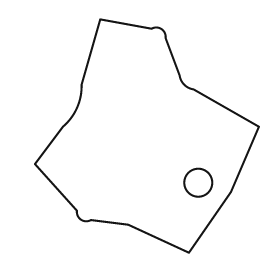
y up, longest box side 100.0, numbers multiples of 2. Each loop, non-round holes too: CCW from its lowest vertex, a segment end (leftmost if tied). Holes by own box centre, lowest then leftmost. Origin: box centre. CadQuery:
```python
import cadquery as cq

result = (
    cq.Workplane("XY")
    .moveTo(18.0, -50.0)
    .lineTo(36.0, -24.0)
    .lineTo(48.0, 4.0)
    .lineTo(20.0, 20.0)
    .threePointArc((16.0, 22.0), (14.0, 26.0))
    .lineTo(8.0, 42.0)
    .threePointArc((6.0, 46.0), (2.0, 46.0))
    .lineTo(-20.0, 50.0)
    .lineTo(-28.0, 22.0)
    .threePointArc((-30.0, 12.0), (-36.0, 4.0))
    .lineTo(-48.0, -12.0)
    .lineTo(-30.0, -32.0)
    .threePointArc((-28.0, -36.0), (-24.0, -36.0))
    .lineTo(-8.0, -38.0)
    .close()
    .moveTo(22.0, -20.0)
    .circle(6.0)
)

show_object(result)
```